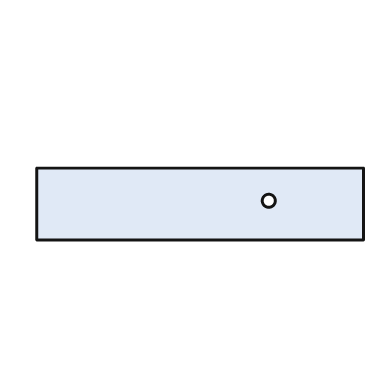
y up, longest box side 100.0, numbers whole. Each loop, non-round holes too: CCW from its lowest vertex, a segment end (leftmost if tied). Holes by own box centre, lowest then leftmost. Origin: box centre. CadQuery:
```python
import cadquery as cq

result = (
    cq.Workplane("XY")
    .moveTo(-50.0, -11.0)
    .lineTo(50.0, -11.0)
    .lineTo(50.0, 11.0)
    .lineTo(-50.0, 11.0)
    .close()
    .moveTo(21.0, 1.0)
    .circle(2.0)
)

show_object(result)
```